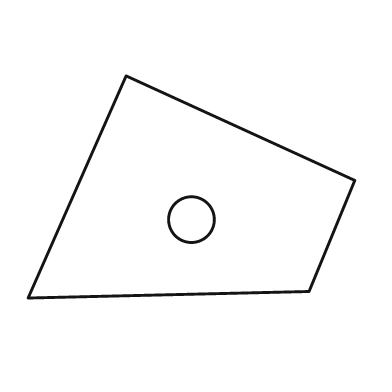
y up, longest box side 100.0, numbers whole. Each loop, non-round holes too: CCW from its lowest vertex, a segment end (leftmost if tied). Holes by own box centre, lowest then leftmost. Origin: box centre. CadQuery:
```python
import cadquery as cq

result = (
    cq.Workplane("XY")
    .moveTo(-50.0, -34.0)
    .lineTo(36.0, -32.0)
    .lineTo(50.0, 2.0)
    .lineTo(-20.0, 34.0)
    .close()
    .moveTo(0.0, -10.0)
    .circle(7.0)
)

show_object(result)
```